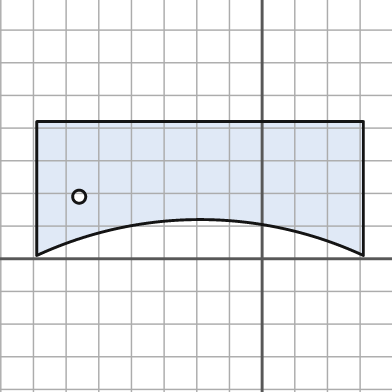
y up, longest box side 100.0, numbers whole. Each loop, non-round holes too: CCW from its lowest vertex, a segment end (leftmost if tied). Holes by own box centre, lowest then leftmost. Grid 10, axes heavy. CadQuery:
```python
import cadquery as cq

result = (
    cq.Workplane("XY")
    .moveTo(-69.0, 1.0)
    .threePointArc((-19.0, 12.0), (31.0, 1.0))
    .lineTo(31.0, 42.0)
    .lineTo(-69.0, 42.0)
    .close()
    .moveTo(-56.0, 19.0)
    .circle(2.0)
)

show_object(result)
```